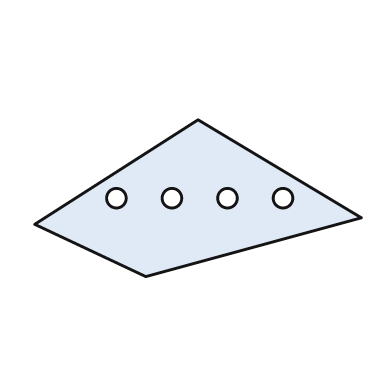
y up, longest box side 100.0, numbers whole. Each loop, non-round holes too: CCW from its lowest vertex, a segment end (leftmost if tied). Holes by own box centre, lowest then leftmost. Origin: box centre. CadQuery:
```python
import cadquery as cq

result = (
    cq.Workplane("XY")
    .moveTo(-16.0, -24.0)
    .lineTo(50.0, -6.0)
    .lineTo(0.0, 24.0)
    .lineTo(-50.0, -8.0)
    .close()
    .moveTo(-25.0, 0.0)
    .circle(3.0)
    .moveTo(-8.0, 0.0)
    .circle(3.0)
    .moveTo(9.0, 0.0)
    .circle(3.0)
    .moveTo(26.0, 0.0)
    .circle(3.0)
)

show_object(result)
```